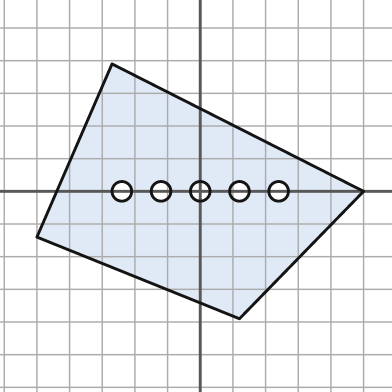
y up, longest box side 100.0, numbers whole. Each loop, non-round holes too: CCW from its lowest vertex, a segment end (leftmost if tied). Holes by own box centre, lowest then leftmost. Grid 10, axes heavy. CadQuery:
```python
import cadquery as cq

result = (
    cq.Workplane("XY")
    .moveTo(12.0, -39.0)
    .lineTo(50.0, 0.0)
    .lineTo(-27.0, 39.0)
    .lineTo(-50.0, -14.0)
    .close()
    .moveTo(-24.0, 0.0)
    .circle(3.0)
    .moveTo(-12.0, 0.0)
    .circle(3.0)
    .moveTo(0.0, 0.0)
    .circle(3.0)
    .moveTo(12.0, 0.0)
    .circle(3.0)
    .moveTo(24.0, 0.0)
    .circle(3.0)
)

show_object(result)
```